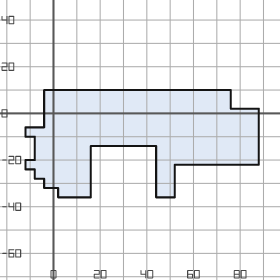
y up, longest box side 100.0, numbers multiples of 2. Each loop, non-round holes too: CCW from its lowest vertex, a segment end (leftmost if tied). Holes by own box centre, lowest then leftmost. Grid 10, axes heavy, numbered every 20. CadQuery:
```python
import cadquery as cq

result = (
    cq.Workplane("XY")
    .moveTo(2.0, -36.0)
    .lineTo(16.0, -36.0)
    .lineTo(16.0, -14.0)
    .lineTo(44.0, -14.0)
    .lineTo(44.0, -36.0)
    .lineTo(52.0, -36.0)
    .lineTo(52.0, -22.0)
    .lineTo(88.0, -22.0)
    .lineTo(88.0, 2.0)
    .lineTo(76.0, 2.0)
    .lineTo(76.0, 10.0)
    .lineTo(-4.0, 10.0)
    .lineTo(-4.0, -6.0)
    .lineTo(-12.0, -6.0)
    .lineTo(-12.0, -10.0)
    .lineTo(-8.0, -10.0)
    .lineTo(-8.0, -20.0)
    .lineTo(-12.0, -20.0)
    .lineTo(-12.0, -24.0)
    .lineTo(-8.0, -24.0)
    .lineTo(-8.0, -28.0)
    .lineTo(-4.0, -28.0)
    .lineTo(-4.0, -32.0)
    .lineTo(2.0, -32.0)
    .close()
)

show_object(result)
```